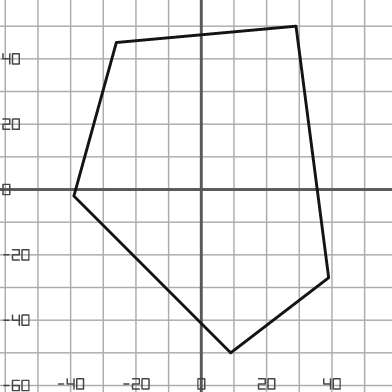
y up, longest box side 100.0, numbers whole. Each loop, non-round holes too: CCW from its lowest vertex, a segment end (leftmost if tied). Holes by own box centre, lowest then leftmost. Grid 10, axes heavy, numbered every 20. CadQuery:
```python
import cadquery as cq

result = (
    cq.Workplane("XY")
    .moveTo(9.0, -50.0)
    .lineTo(39.0, -27.0)
    .lineTo(29.0, 50.0)
    .lineTo(-26.0, 45.0)
    .lineTo(-39.0, -2.0)
    .close()
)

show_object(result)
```